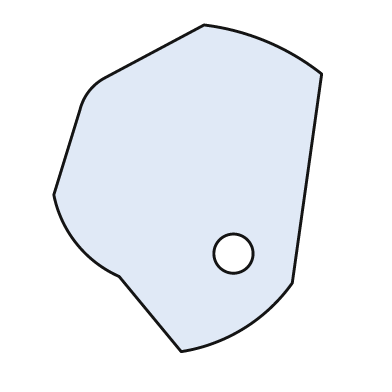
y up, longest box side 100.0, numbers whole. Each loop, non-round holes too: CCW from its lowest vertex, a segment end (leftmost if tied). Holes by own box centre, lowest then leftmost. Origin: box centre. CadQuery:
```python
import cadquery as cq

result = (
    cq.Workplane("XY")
    .moveTo(-2.0, -50.0)
    .threePointArc((17.0, -43.0), (32.0, -29.0))
    .lineTo(41.0, 35.0)
    .threePointArc((24.0, 45.0), (5.0, 50.0))
    .lineTo(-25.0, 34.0)
    .threePointArc((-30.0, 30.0), (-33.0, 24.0))
    .lineTo(-41.0, -2.0)
    .threePointArc((-34.0, -17.0), (-21.0, -27.0))
    .close()
    .moveTo(14.0, -20.0)
    .circle(6.0)
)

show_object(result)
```